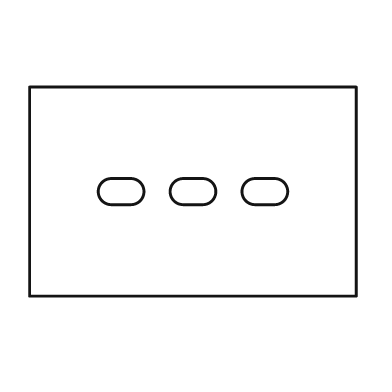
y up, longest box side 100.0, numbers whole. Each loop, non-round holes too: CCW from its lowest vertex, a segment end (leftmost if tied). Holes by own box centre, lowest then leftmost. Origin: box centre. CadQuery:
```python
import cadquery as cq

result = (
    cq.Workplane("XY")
    .moveTo(-50.0, -32.0)
    .lineTo(50.0, -32.0)
    .lineTo(50.0, 32.0)
    .lineTo(-50.0, 32.0)
    .close()
    .moveTo(-25.0, -4.0)
    .lineTo(-19.0, -4.0)
    .threePointArc((-15.0, 0.0), (-19.0, 4.0))
    .lineTo(-25.0, 4.0)
    .threePointArc((-29.0, 0.0), (-25.0, -4.0))
    .close()
    .moveTo(-3.0, -4.0)
    .lineTo(3.0, -4.0)
    .threePointArc((7.0, 0.0), (3.0, 4.0))
    .lineTo(-3.0, 4.0)
    .threePointArc((-7.0, 0.0), (-3.0, -4.0))
    .close()
    .moveTo(19.0, -4.0)
    .lineTo(25.0, -4.0)
    .threePointArc((29.0, 0.0), (25.0, 4.0))
    .lineTo(19.0, 4.0)
    .threePointArc((15.0, 0.0), (19.0, -4.0))
    .close()
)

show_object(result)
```